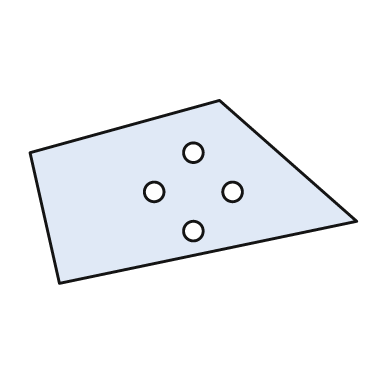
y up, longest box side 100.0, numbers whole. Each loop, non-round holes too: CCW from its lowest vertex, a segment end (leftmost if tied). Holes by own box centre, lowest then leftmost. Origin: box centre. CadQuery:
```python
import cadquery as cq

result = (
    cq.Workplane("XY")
    .moveTo(-41.0, -28.0)
    .lineTo(50.0, -9.0)
    .lineTo(8.0, 28.0)
    .lineTo(-50.0, 12.0)
    .close()
    .moveTo(0.0, -12.0)
    .circle(3.0)
    .moveTo(-12.0, 0.0)
    .circle(3.0)
    .moveTo(12.0, 0.0)
    .circle(3.0)
    .moveTo(0.0, 12.0)
    .circle(3.0)
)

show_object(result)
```